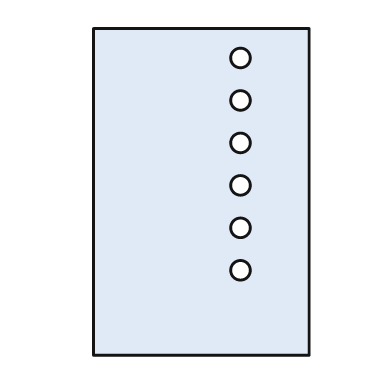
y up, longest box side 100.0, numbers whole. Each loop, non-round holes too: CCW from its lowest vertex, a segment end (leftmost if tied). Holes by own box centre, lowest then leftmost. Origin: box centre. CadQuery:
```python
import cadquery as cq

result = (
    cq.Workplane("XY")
    .moveTo(-33.0, -50.0)
    .lineTo(33.0, -50.0)
    .lineTo(33.0, 50.0)
    .lineTo(-33.0, 50.0)
    .close()
    .moveTo(12.0, -24.0)
    .circle(3.0)
    .moveTo(12.0, -11.0)
    .circle(3.0)
    .moveTo(12.0, 2.0)
    .circle(3.0)
    .moveTo(12.0, 15.0)
    .circle(3.0)
    .moveTo(12.0, 28.0)
    .circle(3.0)
    .moveTo(12.0, 41.0)
    .circle(3.0)
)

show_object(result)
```